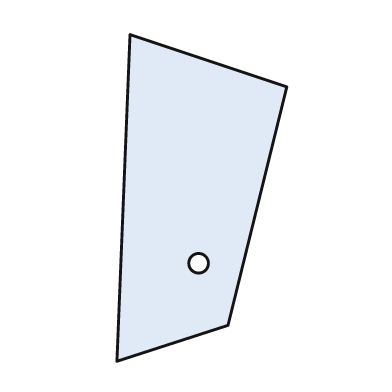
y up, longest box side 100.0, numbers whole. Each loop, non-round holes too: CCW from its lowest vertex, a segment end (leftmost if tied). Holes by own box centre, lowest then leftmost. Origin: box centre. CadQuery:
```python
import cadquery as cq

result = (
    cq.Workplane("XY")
    .moveTo(-26.0, -50.0)
    .lineTo(8.0, -39.0)
    .lineTo(26.0, 34.0)
    .lineTo(-22.0, 50.0)
    .close()
    .moveTo(-1.0, -20.0)
    .circle(3.0)
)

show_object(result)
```